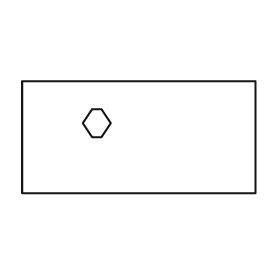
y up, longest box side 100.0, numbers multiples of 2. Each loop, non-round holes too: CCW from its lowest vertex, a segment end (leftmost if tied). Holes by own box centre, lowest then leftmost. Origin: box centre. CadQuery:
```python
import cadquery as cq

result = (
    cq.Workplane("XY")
    .moveTo(-50.0, -24.0)
    .lineTo(50.0, -24.0)
    .lineTo(50.0, 24.0)
    .lineTo(-50.0, 24.0)
    .close()
    .moveTo(-20.0, 0.0)
    .lineTo(-16.0, 0.0)
    .lineTo(-12.0, 6.0)
    .lineTo(-16.0, 12.0)
    .lineTo(-20.0, 12.0)
    .lineTo(-24.0, 6.0)
    .close()
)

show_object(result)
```